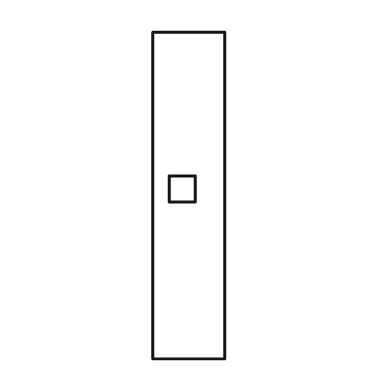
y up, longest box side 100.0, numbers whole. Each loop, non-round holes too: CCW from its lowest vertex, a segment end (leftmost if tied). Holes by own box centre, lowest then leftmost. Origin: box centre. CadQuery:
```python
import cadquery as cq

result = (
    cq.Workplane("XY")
    .moveTo(-11.0, -50.0)
    .lineTo(11.0, -50.0)
    .lineTo(11.0, 50.0)
    .lineTo(-11.0, 50.0)
    .close()
    .moveTo(-6.0, -2.0)
    .lineTo(2.0, -2.0)
    .lineTo(2.0, 6.0)
    .lineTo(-6.0, 6.0)
    .close()
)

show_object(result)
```